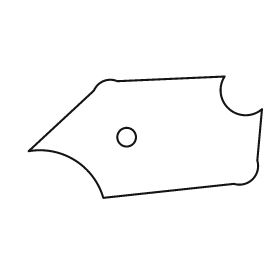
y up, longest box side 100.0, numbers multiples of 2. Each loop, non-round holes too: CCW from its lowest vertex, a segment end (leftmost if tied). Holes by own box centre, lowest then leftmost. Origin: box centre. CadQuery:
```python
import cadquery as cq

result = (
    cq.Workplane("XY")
    .moveTo(-18.0, -26.0)
    .lineTo(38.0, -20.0)
    .threePointArc((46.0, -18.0), (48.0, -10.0))
    .lineTo(50.0, 12.0)
    .threePointArc((36.0, 12.0), (34.0, 26.0))
    .lineTo(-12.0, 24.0)
    .threePointArc((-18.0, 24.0), (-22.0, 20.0))
    .lineTo(-50.0, -6.0)
    .threePointArc((-30.0, -10.0), (-18.0, -26.0))
    .close()
    .moveTo(-8.0, 0.0)
    .circle(4.0)
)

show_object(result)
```